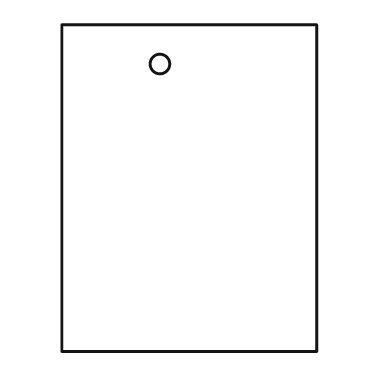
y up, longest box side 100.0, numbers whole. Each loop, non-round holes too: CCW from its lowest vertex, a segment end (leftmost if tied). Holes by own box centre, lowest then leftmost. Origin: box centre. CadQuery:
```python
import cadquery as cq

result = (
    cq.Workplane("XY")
    .moveTo(-39.0, -50.0)
    .lineTo(39.0, -50.0)
    .lineTo(39.0, 50.0)
    .lineTo(-39.0, 50.0)
    .close()
    .moveTo(-9.0, 38.0)
    .circle(3.0)
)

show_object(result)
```